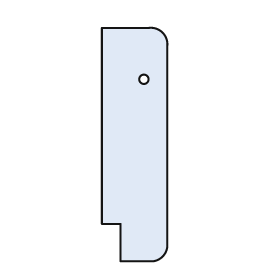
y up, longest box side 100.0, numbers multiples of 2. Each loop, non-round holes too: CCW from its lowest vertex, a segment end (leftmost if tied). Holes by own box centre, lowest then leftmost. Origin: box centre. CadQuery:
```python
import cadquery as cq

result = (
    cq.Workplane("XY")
    .moveTo(-6.0, -50.0)
    .lineTo(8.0, -50.0)
    .threePointArc((12.0, -48.0), (14.0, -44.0))
    .lineTo(14.0, 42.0)
    .threePointArc((12.0, 48.0), (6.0, 50.0))
    .lineTo(-14.0, 50.0)
    .lineTo(-14.0, -34.0)
    .lineTo(-6.0, -34.0)
    .close()
    .moveTo(4.0, 28.0)
    .circle(2.0)
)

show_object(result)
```